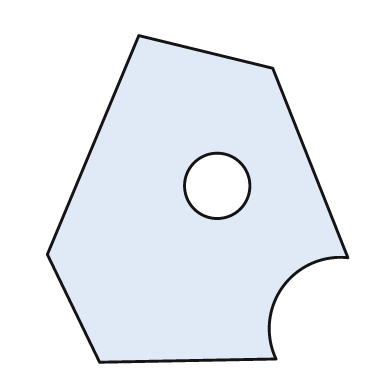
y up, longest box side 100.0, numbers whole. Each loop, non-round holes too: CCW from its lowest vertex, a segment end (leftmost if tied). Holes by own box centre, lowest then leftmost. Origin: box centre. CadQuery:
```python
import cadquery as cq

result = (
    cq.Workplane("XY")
    .moveTo(-30.0, -50.0)
    .lineTo(24.0, -49.0)
    .threePointArc((26.0, -27.0), (46.0, -18.0))
    .lineTo(23.0, 40.0)
    .lineTo(-18.0, 50.0)
    .lineTo(-46.0, -17.0)
    .close()
    .moveTo(6.0, 4.0)
    .circle(10.0)
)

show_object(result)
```